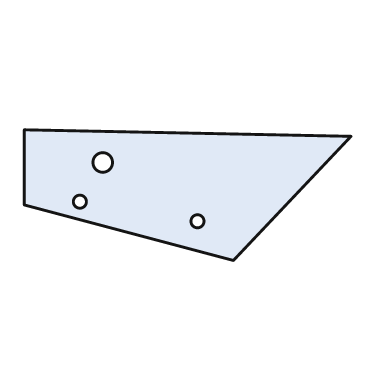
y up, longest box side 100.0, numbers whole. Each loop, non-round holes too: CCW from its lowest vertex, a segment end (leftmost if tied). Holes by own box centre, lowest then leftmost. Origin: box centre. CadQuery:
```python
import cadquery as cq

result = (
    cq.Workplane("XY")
    .moveTo(14.0, -20.0)
    .lineTo(50.0, 18.0)
    .lineTo(-50.0, 20.0)
    .lineTo(-50.0, -3.0)
    .close()
    .moveTo(3.0, -8.0)
    .circle(2.0)
    .moveTo(-33.0, -2.0)
    .circle(2.0)
    .moveTo(-26.0, 10.0)
    .circle(3.0)
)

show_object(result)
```